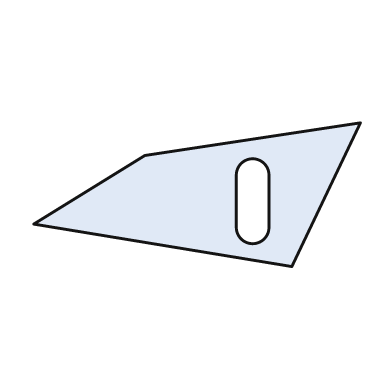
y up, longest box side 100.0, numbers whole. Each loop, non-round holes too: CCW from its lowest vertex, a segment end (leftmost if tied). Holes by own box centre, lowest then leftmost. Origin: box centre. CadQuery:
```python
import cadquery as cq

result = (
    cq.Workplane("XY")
    .moveTo(29.0, -22.0)
    .lineTo(50.0, 22.0)
    .lineTo(-16.0, 12.0)
    .lineTo(-50.0, -9.0)
    .close()
    .moveTo(12.0, -10.0)
    .threePointArc((17.0, -15.0), (22.0, -10.0))
    .lineTo(22.0, 6.0)
    .threePointArc((17.0, 11.0), (12.0, 6.0))
    .close()
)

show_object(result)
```